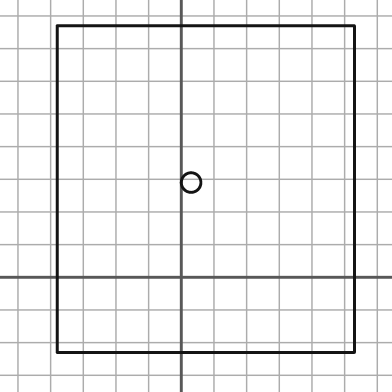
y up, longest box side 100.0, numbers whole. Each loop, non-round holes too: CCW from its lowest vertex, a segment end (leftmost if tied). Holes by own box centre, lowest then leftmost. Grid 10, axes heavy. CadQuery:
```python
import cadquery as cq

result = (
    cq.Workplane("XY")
    .moveTo(-38.0, -23.0)
    .lineTo(53.0, -23.0)
    .lineTo(53.0, 77.0)
    .lineTo(-38.0, 77.0)
    .close()
    .moveTo(3.0, 29.0)
    .circle(3.0)
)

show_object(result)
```